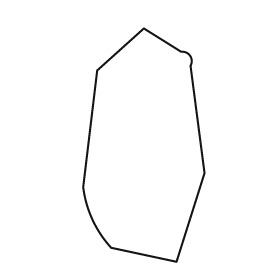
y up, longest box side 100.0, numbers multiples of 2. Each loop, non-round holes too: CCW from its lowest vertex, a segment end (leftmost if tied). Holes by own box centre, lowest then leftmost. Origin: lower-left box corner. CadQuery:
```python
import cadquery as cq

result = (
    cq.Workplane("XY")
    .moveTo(40.0, 0.0)
    .lineTo(52.0, 38.0)
    .lineTo(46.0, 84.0)
    .threePointArc((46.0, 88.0), (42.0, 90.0))
    .lineTo(26.0, 100.0)
    .lineTo(6.0, 82.0)
    .lineTo(0.0, 32.0)
    .threePointArc((4.0, 18.0), (12.0, 6.0))
    .close()
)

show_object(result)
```